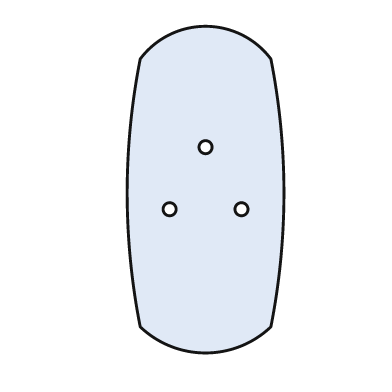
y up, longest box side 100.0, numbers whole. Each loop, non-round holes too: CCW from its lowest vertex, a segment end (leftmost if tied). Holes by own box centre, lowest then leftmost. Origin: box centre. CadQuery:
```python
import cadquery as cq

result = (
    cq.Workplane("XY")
    .moveTo(-20.0, -42.0)
    .threePointArc((0.0, -50.0), (20.0, -42.0))
    .threePointArc((24.0, -1.0), (20.0, 40.0))
    .threePointArc((0.0, 50.0), (-20.0, 40.0))
    .threePointArc((-24.0, -1.0), (-20.0, -42.0))
    .close()
    .moveTo(-11.0, -6.0)
    .circle(2.0)
    .moveTo(11.0, -6.0)
    .circle(2.0)
    .moveTo(0.0, 13.0)
    .circle(2.0)
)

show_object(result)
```